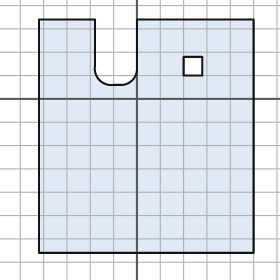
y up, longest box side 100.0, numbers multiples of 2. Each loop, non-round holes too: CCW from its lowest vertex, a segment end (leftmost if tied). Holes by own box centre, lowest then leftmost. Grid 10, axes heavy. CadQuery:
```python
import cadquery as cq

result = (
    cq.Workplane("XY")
    .moveTo(-42.0, -66.0)
    .lineTo(50.0, -66.0)
    .lineTo(50.0, 34.0)
    .lineTo(0.0, 34.0)
    .lineTo(0.0, 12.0)
    .threePointArc((-2.0, 8.0), (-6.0, 6.0))
    .lineTo(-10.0, 6.0)
    .threePointArc((-16.0, 8.0), (-18.0, 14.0))
    .lineTo(-18.0, 34.0)
    .lineTo(-42.0, 34.0)
    .close()
    .moveTo(20.0, 10.0)
    .lineTo(28.0, 10.0)
    .lineTo(28.0, 18.0)
    .lineTo(20.0, 18.0)
    .close()
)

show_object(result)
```